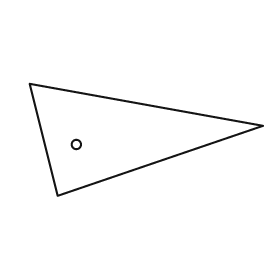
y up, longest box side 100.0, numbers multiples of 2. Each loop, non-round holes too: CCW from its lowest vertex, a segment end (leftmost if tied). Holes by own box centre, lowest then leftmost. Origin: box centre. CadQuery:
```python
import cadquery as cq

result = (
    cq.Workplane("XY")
    .moveTo(-38.0, -24.0)
    .lineTo(50.0, 6.0)
    .lineTo(-50.0, 24.0)
    .close()
    .moveTo(-30.0, -2.0)
    .circle(2.0)
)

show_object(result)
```